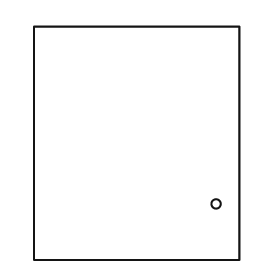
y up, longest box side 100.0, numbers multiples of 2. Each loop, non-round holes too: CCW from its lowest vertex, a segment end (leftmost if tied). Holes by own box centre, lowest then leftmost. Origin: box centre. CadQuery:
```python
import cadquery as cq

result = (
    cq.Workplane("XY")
    .moveTo(-44.0, -50.0)
    .lineTo(44.0, -50.0)
    .lineTo(44.0, 50.0)
    .lineTo(-44.0, 50.0)
    .close()
    .moveTo(34.0, -26.0)
    .circle(2.0)
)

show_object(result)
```